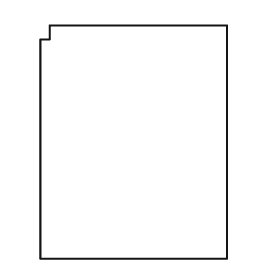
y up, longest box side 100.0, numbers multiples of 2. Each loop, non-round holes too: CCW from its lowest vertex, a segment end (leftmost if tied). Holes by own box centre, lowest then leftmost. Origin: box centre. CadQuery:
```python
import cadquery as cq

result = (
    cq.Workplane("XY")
    .moveTo(-40.0, -50.0)
    .lineTo(40.0, -50.0)
    .lineTo(40.0, 50.0)
    .lineTo(-36.0, 50.0)
    .lineTo(-36.0, 44.0)
    .lineTo(-40.0, 44.0)
    .close()
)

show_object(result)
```